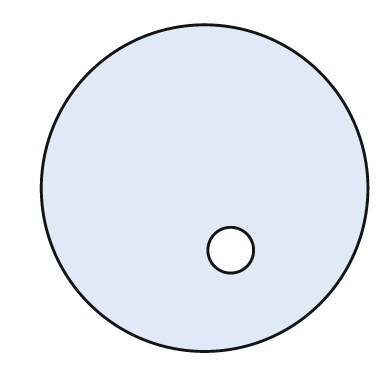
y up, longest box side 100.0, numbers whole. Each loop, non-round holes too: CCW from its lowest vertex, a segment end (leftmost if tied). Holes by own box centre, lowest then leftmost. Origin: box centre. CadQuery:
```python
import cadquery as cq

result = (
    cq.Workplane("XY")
    .moveTo(0.0, 0.0)
    .circle(50.0)
    .moveTo(8.0, -19.0)
    .circle(7.0)
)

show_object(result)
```